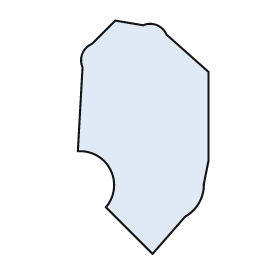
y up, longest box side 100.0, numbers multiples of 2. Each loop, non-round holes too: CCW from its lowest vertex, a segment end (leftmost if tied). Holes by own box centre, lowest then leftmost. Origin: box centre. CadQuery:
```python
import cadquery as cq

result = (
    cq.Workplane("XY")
    .moveTo(4.0, -50.0)
    .lineTo(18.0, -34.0)
    .threePointArc((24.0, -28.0), (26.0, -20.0))
    .lineTo(28.0, -10.0)
    .lineTo(28.0, 28.0)
    .lineTo(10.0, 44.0)
    .threePointArc((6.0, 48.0), (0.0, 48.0))
    .lineTo(-12.0, 50.0)
    .lineTo(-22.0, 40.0)
    .threePointArc((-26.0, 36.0), (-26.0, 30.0))
    .lineTo(-28.0, -6.0)
    .threePointArc((-14.0, -14.0), (-16.0, -30.0))
    .close()
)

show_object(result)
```